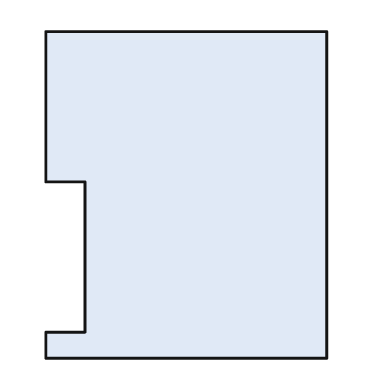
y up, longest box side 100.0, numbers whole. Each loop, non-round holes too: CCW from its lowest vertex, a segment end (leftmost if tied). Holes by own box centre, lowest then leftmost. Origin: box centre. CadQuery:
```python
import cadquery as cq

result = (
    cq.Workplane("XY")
    .moveTo(-43.0, -50.0)
    .lineTo(43.0, -50.0)
    .lineTo(43.0, 50.0)
    .lineTo(-43.0, 50.0)
    .lineTo(-43.0, 4.0)
    .lineTo(-31.0, 4.0)
    .lineTo(-31.0, -42.0)
    .lineTo(-43.0, -42.0)
    .close()
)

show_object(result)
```